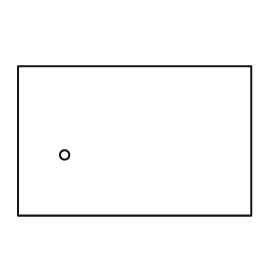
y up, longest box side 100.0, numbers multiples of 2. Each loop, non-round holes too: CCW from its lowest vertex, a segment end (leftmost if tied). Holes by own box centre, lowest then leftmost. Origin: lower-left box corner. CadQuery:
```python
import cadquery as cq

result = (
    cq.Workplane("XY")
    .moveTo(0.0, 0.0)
    .lineTo(100.0, 0.0)
    .lineTo(100.0, 64.0)
    .lineTo(0.0, 64.0)
    .close()
    .moveTo(20.0, 26.0)
    .circle(2.0)
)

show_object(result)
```